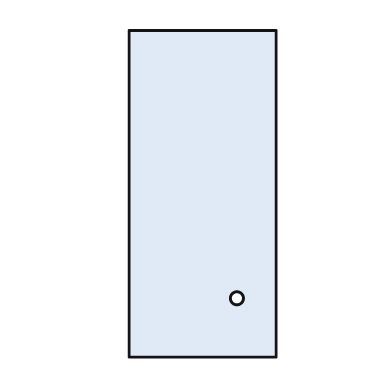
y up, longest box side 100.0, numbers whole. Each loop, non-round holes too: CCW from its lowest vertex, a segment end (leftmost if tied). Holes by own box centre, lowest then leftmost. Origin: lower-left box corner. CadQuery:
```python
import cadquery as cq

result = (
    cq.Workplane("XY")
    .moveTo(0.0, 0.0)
    .lineTo(45.0, 0.0)
    .lineTo(45.0, 100.0)
    .lineTo(0.0, 100.0)
    .close()
    .moveTo(33.0, 18.0)
    .circle(2.0)
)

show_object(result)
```